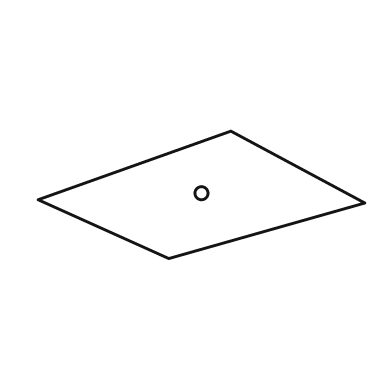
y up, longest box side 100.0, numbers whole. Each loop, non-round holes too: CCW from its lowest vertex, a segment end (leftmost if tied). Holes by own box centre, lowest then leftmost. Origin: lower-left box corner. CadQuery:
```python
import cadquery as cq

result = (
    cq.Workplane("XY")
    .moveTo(40.0, 0.0)
    .lineTo(100.0, 17.0)
    .lineTo(59.0, 39.0)
    .lineTo(0.0, 18.0)
    .close()
    .moveTo(50.0, 20.0)
    .circle(2.0)
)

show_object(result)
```